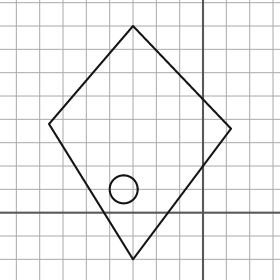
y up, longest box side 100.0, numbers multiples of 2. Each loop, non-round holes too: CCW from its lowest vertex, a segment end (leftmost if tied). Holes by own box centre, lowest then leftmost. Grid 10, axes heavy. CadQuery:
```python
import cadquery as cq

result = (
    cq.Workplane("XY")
    .moveTo(-30.0, -20.0)
    .lineTo(12.0, 36.0)
    .lineTo(-30.0, 80.0)
    .lineTo(-66.0, 38.0)
    .close()
    .moveTo(-34.0, 10.0)
    .circle(6.0)
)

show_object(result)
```